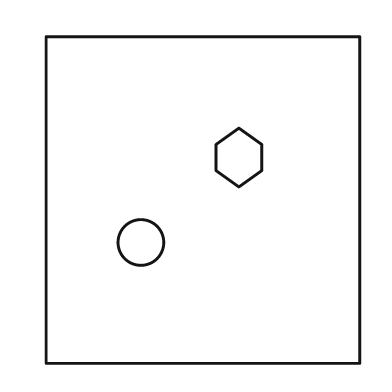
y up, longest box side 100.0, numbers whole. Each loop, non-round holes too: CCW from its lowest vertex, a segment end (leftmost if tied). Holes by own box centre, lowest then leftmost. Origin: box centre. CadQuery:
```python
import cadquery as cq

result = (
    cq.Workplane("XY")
    .moveTo(-48.0, -50.0)
    .lineTo(48.0, -50.0)
    .lineTo(48.0, 50.0)
    .lineTo(-48.0, 50.0)
    .close()
    .moveTo(-19.0, -13.0)
    .circle(7.0)
    .moveTo(11.0, 4.0)
    .lineTo(18.0, 9.0)
    .lineTo(18.0, 17.0)
    .lineTo(11.0, 22.0)
    .lineTo(4.0, 17.0)
    .lineTo(4.0, 9.0)
    .close()
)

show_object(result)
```